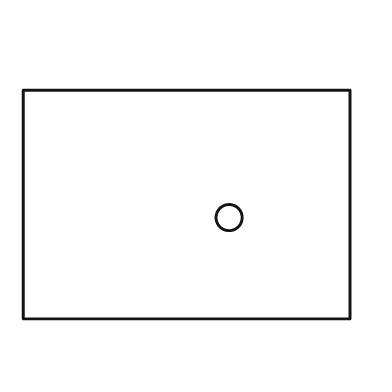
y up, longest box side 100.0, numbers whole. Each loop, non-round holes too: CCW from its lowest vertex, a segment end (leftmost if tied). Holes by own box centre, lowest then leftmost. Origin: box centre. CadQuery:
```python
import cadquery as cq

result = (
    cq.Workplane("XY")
    .moveTo(-50.0, -35.0)
    .lineTo(50.0, -35.0)
    .lineTo(50.0, 35.0)
    .lineTo(-50.0, 35.0)
    .close()
    .moveTo(13.0, -4.0)
    .circle(4.0)
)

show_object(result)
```